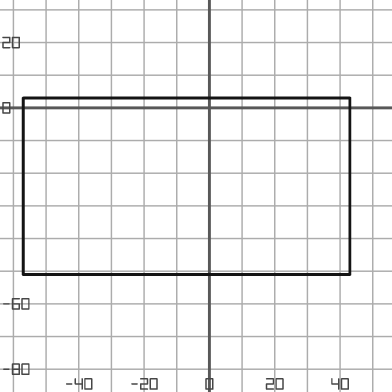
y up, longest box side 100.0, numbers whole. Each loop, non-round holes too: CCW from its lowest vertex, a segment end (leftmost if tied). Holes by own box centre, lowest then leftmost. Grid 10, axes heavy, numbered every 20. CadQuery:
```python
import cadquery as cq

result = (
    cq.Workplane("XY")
    .moveTo(-57.0, -51.0)
    .lineTo(43.0, -51.0)
    .lineTo(43.0, 3.0)
    .lineTo(-57.0, 3.0)
    .close()
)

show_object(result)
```